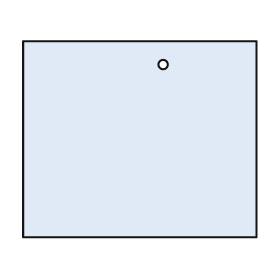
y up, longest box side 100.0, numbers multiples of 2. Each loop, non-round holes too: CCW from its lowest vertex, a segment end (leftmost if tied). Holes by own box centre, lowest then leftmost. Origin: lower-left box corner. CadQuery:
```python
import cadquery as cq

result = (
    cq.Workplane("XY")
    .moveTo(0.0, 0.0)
    .lineTo(100.0, 0.0)
    .lineTo(100.0, 84.0)
    .lineTo(0.0, 84.0)
    .close()
    .moveTo(60.0, 74.0)
    .circle(2.0)
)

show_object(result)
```